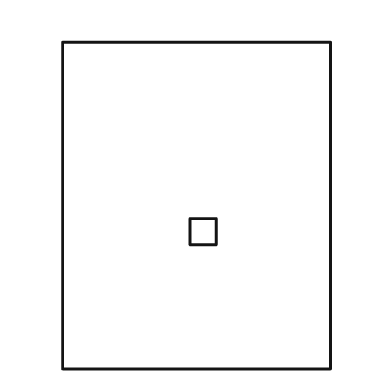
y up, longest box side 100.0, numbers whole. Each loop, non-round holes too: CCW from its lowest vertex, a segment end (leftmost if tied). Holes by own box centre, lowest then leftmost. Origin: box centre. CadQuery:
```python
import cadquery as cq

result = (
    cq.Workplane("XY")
    .moveTo(-41.0, -50.0)
    .lineTo(41.0, -50.0)
    .lineTo(41.0, 50.0)
    .lineTo(-41.0, 50.0)
    .close()
    .moveTo(-2.0, -12.0)
    .lineTo(6.0, -12.0)
    .lineTo(6.0, -4.0)
    .lineTo(-2.0, -4.0)
    .close()
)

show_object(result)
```